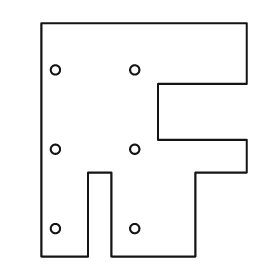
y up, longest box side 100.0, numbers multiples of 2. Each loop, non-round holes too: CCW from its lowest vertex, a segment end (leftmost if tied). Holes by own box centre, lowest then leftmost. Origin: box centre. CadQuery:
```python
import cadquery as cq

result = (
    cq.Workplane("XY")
    .moveTo(-44.0, -50.0)
    .lineTo(-24.0, -50.0)
    .lineTo(-24.0, -14.0)
    .lineTo(-14.0, -14.0)
    .lineTo(-14.0, -50.0)
    .lineTo(22.0, -50.0)
    .lineTo(22.0, -14.0)
    .lineTo(44.0, -14.0)
    .lineTo(44.0, 0.0)
    .lineTo(6.0, 0.0)
    .lineTo(6.0, 24.0)
    .lineTo(44.0, 24.0)
    .lineTo(44.0, 50.0)
    .lineTo(-44.0, 50.0)
    .close()
    .moveTo(-38.0, -38.0)
    .circle(2.0)
    .moveTo(-4.0, -38.0)
    .circle(2.0)
    .moveTo(-38.0, -4.0)
    .circle(2.0)
    .moveTo(-4.0, -4.0)
    .circle(2.0)
    .moveTo(-38.0, 30.0)
    .circle(2.0)
    .moveTo(-4.0, 30.0)
    .circle(2.0)
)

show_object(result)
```